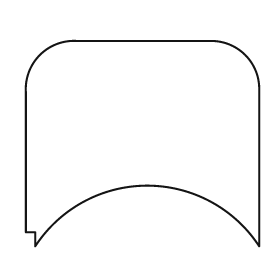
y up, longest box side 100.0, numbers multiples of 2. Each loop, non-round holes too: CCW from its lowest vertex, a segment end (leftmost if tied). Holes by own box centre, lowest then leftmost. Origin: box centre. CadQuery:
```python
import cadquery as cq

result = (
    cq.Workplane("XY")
    .moveTo(-46.0, -44.0)
    .threePointArc((2.0, -18.0), (50.0, -44.0))
    .lineTo(50.0, 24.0)
    .threePointArc((44.0, 38.0), (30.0, 44.0))
    .lineTo(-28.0, 44.0)
    .threePointArc((-44.0, 38.0), (-50.0, 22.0))
    .lineTo(-50.0, -38.0)
    .lineTo(-46.0, -38.0)
    .close()
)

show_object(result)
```